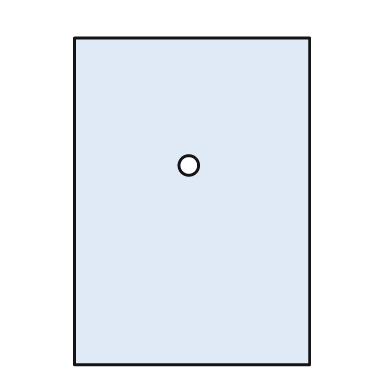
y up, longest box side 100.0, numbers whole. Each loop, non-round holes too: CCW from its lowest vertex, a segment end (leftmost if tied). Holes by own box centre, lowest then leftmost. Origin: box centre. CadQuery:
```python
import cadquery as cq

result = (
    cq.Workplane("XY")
    .moveTo(-36.0, -50.0)
    .lineTo(36.0, -50.0)
    .lineTo(36.0, 50.0)
    .lineTo(-36.0, 50.0)
    .close()
    .moveTo(-1.0, 11.0)
    .circle(3.0)
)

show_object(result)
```